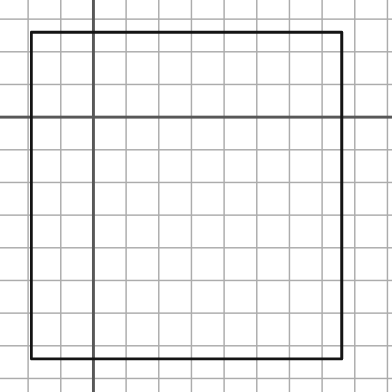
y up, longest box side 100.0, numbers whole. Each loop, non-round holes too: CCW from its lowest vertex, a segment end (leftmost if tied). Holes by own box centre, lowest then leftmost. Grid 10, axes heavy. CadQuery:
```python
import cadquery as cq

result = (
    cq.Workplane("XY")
    .moveTo(-19.0, -74.0)
    .lineTo(76.0, -74.0)
    .lineTo(76.0, 26.0)
    .lineTo(-19.0, 26.0)
    .close()
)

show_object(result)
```